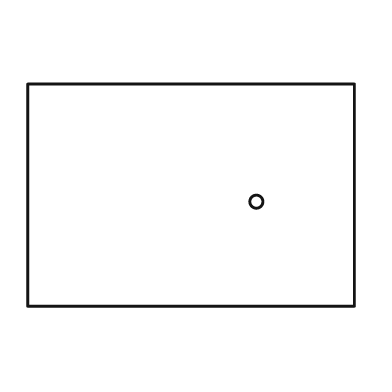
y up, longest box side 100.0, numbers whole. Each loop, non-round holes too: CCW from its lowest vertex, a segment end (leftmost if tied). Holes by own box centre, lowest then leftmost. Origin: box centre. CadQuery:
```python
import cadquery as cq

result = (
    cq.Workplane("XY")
    .moveTo(-50.0, -34.0)
    .lineTo(50.0, -34.0)
    .lineTo(50.0, 34.0)
    .lineTo(-50.0, 34.0)
    .close()
    .moveTo(20.0, -2.0)
    .circle(2.0)
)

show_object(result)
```